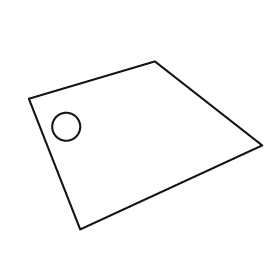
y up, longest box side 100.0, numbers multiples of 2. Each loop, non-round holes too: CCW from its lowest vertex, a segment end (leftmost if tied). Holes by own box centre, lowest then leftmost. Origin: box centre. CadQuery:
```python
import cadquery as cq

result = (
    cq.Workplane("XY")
    .moveTo(-28.0, -36.0)
    .lineTo(50.0, 0.0)
    .lineTo(4.0, 36.0)
    .lineTo(-50.0, 20.0)
    .close()
    .moveTo(-34.0, 8.0)
    .circle(6.0)
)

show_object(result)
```